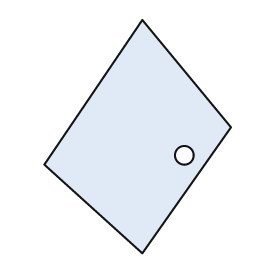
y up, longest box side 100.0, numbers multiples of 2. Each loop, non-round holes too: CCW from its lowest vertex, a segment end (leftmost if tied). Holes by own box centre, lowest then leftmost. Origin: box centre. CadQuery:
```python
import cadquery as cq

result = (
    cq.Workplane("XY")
    .moveTo(2.0, -50.0)
    .lineTo(40.0, 4.0)
    .lineTo(2.0, 50.0)
    .lineTo(-40.0, -12.0)
    .close()
    .moveTo(20.0, -8.0)
    .circle(4.0)
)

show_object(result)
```